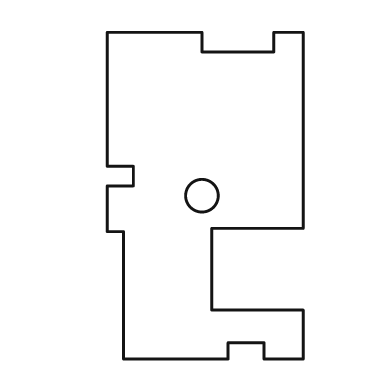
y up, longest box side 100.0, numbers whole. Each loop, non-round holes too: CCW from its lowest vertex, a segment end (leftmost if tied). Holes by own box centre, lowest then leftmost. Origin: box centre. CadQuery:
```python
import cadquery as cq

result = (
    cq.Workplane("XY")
    .moveTo(-25.0, -50.0)
    .lineTo(7.0, -50.0)
    .lineTo(7.0, -45.0)
    .lineTo(18.0, -45.0)
    .lineTo(18.0, -50.0)
    .lineTo(30.0, -50.0)
    .lineTo(30.0, -35.0)
    .lineTo(2.0, -35.0)
    .lineTo(2.0, -10.0)
    .lineTo(30.0, -10.0)
    .lineTo(30.0, 50.0)
    .lineTo(21.0, 50.0)
    .lineTo(21.0, 44.0)
    .lineTo(-1.0, 44.0)
    .lineTo(-1.0, 50.0)
    .lineTo(-30.0, 50.0)
    .lineTo(-30.0, 9.0)
    .lineTo(-22.0, 9.0)
    .lineTo(-22.0, 3.0)
    .lineTo(-30.0, 3.0)
    .lineTo(-30.0, -11.0)
    .lineTo(-25.0, -11.0)
    .close()
    .moveTo(-1.0, 0.0)
    .circle(5.0)
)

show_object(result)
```